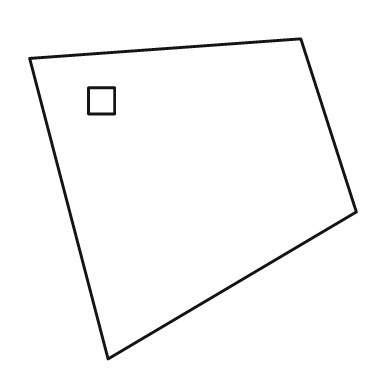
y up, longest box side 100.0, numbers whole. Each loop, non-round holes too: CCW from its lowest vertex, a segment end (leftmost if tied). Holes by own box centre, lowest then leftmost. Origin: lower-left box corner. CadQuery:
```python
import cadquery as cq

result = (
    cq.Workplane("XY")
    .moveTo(24.0, 0.0)
    .lineTo(100.0, 45.0)
    .lineTo(83.0, 98.0)
    .lineTo(0.0, 92.0)
    .close()
    .moveTo(18.0, 75.0)
    .lineTo(26.0, 75.0)
    .lineTo(26.0, 83.0)
    .lineTo(18.0, 83.0)
    .close()
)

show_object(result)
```